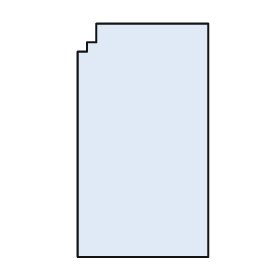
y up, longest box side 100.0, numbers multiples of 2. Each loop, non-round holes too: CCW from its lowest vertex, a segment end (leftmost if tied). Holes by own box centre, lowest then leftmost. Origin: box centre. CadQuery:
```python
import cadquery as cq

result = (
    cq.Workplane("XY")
    .moveTo(-28.0, -50.0)
    .lineTo(28.0, -50.0)
    .lineTo(28.0, 50.0)
    .lineTo(-20.0, 50.0)
    .lineTo(-20.0, 42.0)
    .lineTo(-24.0, 42.0)
    .lineTo(-24.0, 38.0)
    .lineTo(-28.0, 38.0)
    .close()
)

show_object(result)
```